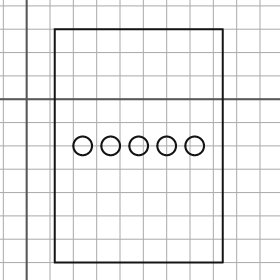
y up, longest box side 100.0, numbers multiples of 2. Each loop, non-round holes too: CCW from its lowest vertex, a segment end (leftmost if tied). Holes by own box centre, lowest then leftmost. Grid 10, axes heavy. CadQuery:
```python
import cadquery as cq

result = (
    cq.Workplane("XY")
    .moveTo(12.0, -70.0)
    .lineTo(84.0, -70.0)
    .lineTo(84.0, 30.0)
    .lineTo(12.0, 30.0)
    .close()
    .moveTo(24.0, -20.0)
    .circle(4.0)
    .moveTo(36.0, -20.0)
    .circle(4.0)
    .moveTo(48.0, -20.0)
    .circle(4.0)
    .moveTo(60.0, -20.0)
    .circle(4.0)
    .moveTo(72.0, -20.0)
    .circle(4.0)
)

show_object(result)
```